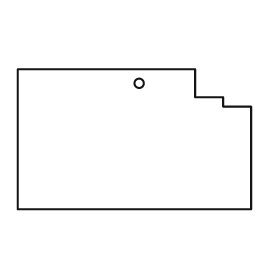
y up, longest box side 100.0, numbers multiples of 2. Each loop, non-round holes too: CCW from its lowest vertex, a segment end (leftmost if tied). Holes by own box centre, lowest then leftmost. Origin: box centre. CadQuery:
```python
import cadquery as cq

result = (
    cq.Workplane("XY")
    .moveTo(-50.0, -30.0)
    .lineTo(50.0, -30.0)
    .lineTo(50.0, 14.0)
    .lineTo(38.0, 14.0)
    .lineTo(38.0, 18.0)
    .lineTo(26.0, 18.0)
    .lineTo(26.0, 30.0)
    .lineTo(-50.0, 30.0)
    .close()
    .moveTo(2.0, 24.0)
    .circle(2.0)
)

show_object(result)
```